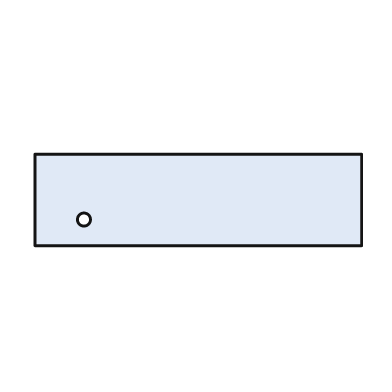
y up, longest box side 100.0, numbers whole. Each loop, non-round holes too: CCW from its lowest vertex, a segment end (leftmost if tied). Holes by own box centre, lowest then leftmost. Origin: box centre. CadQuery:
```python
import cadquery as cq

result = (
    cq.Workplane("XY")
    .moveTo(-50.0, -14.0)
    .lineTo(50.0, -14.0)
    .lineTo(50.0, 14.0)
    .lineTo(-50.0, 14.0)
    .close()
    .moveTo(-35.0, -6.0)
    .circle(2.0)
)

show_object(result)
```